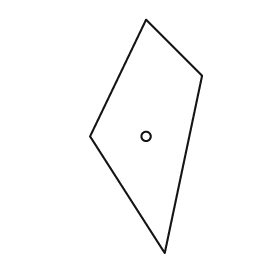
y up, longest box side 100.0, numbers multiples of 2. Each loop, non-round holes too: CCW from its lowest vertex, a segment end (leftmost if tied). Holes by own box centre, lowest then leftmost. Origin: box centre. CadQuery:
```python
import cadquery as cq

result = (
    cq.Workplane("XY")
    .moveTo(8.0, -50.0)
    .lineTo(24.0, 26.0)
    .lineTo(0.0, 50.0)
    .lineTo(-24.0, 0.0)
    .close()
    .moveTo(0.0, 0.0)
    .circle(2.0)
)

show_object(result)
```